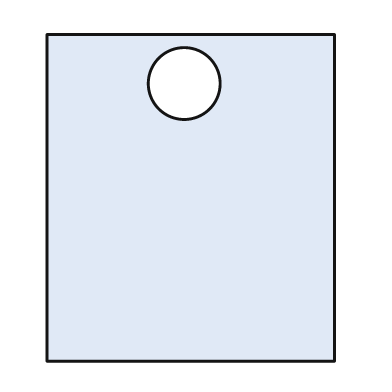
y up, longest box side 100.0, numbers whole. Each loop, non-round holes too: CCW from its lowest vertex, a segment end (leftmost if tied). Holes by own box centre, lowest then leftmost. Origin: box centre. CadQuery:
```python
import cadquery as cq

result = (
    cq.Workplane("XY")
    .moveTo(-44.0, -50.0)
    .lineTo(44.0, -50.0)
    .lineTo(44.0, 50.0)
    .lineTo(-44.0, 50.0)
    .close()
    .moveTo(-2.0, 35.0)
    .circle(11.0)
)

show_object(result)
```